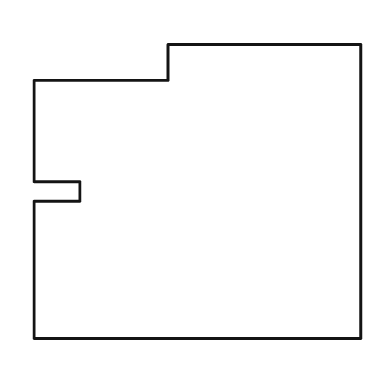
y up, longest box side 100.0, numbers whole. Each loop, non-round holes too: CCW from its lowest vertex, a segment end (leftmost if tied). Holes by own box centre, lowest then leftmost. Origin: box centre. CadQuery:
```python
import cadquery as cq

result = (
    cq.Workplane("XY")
    .moveTo(-50.0, -45.0)
    .lineTo(50.0, -45.0)
    .lineTo(50.0, 45.0)
    .lineTo(-9.0, 45.0)
    .lineTo(-9.0, 34.0)
    .lineTo(-50.0, 34.0)
    .lineTo(-50.0, 3.0)
    .lineTo(-36.0, 3.0)
    .lineTo(-36.0, -3.0)
    .lineTo(-50.0, -3.0)
    .close()
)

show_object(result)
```